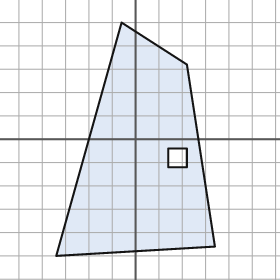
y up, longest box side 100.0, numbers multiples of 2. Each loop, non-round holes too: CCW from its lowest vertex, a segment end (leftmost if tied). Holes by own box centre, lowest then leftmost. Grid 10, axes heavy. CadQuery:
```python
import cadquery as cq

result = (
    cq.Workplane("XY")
    .moveTo(-34.0, -50.0)
    .lineTo(34.0, -46.0)
    .lineTo(22.0, 32.0)
    .lineTo(-6.0, 50.0)
    .close()
    .moveTo(14.0, -12.0)
    .lineTo(22.0, -12.0)
    .lineTo(22.0, -4.0)
    .lineTo(14.0, -4.0)
    .close()
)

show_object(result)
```